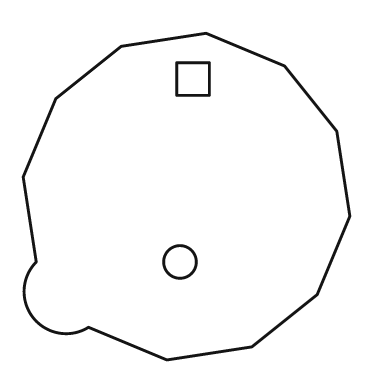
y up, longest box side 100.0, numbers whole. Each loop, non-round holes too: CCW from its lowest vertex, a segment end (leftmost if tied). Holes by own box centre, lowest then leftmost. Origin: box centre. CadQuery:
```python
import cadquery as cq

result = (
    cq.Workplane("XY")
    .moveTo(-6.0, -50.0)
    .lineTo(20.0, -46.0)
    .lineTo(40.0, -30.0)
    .lineTo(50.0, -6.0)
    .lineTo(46.0, 20.0)
    .lineTo(30.0, 40.0)
    .lineTo(6.0, 50.0)
    .lineTo(-20.0, 46.0)
    .lineTo(-40.0, 30.0)
    .lineTo(-50.0, 6.0)
    .lineTo(-46.0, -20.0)
    .threePointArc((-47.0, -37.0), (-30.0, -40.0))
    .close()
    .moveTo(-2.0, -20.0)
    .circle(5.0)
    .moveTo(-3.0, 31.0)
    .lineTo(7.0, 31.0)
    .lineTo(7.0, 41.0)
    .lineTo(-3.0, 41.0)
    .close()
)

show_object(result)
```